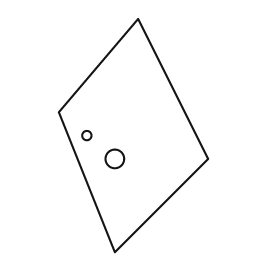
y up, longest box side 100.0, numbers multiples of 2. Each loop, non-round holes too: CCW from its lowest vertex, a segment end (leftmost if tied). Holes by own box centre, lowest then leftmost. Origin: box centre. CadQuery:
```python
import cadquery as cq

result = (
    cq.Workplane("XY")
    .moveTo(-8.0, -50.0)
    .lineTo(32.0, -10.0)
    .lineTo(2.0, 50.0)
    .lineTo(-32.0, 10.0)
    .close()
    .moveTo(-8.0, -10.0)
    .circle(4.0)
    .moveTo(-20.0, 0.0)
    .circle(2.0)
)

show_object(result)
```